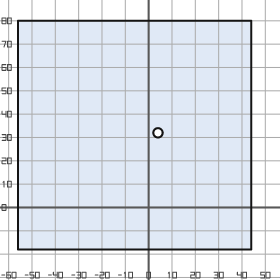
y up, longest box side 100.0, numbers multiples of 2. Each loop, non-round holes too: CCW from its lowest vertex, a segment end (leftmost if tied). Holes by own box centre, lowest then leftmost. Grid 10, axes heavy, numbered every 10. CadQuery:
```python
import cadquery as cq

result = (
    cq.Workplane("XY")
    .moveTo(-56.0, -18.0)
    .lineTo(44.0, -18.0)
    .lineTo(44.0, 80.0)
    .lineTo(-56.0, 80.0)
    .close()
    .moveTo(4.0, 32.0)
    .circle(2.0)
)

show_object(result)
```